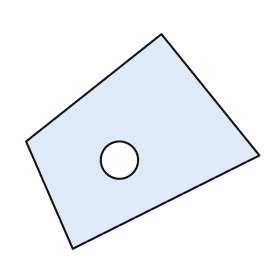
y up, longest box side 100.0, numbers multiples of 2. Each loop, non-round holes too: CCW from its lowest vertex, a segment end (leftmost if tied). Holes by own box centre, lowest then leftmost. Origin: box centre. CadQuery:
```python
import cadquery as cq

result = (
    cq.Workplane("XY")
    .moveTo(-30.0, -46.0)
    .lineTo(50.0, -6.0)
    .lineTo(8.0, 46.0)
    .lineTo(-50.0, 0.0)
    .close()
    .moveTo(-10.0, -8.0)
    .circle(8.0)
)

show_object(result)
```